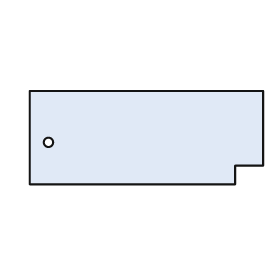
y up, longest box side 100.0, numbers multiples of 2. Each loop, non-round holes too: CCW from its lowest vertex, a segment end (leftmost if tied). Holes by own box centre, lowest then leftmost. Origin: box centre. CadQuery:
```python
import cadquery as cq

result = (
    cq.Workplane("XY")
    .moveTo(-50.0, -20.0)
    .lineTo(38.0, -20.0)
    .lineTo(38.0, -12.0)
    .lineTo(50.0, -12.0)
    .lineTo(50.0, 20.0)
    .lineTo(-50.0, 20.0)
    .close()
    .moveTo(-42.0, -2.0)
    .circle(2.0)
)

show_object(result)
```